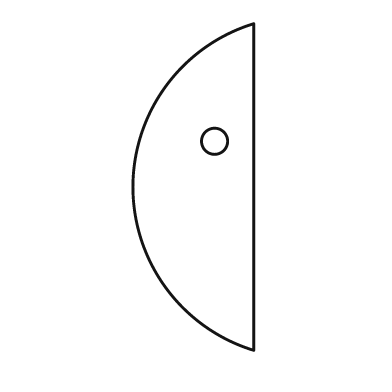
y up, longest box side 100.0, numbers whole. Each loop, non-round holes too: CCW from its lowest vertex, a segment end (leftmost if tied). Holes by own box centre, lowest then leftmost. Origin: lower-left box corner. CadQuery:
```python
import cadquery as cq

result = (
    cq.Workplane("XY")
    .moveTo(37.0, 0.0)
    .lineTo(37.0, 100.0)
    .threePointArc((0.0, 50.0), (37.0, 0.0))
    .close()
    .moveTo(25.0, 64.0)
    .circle(4.0)
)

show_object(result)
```